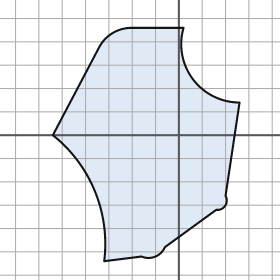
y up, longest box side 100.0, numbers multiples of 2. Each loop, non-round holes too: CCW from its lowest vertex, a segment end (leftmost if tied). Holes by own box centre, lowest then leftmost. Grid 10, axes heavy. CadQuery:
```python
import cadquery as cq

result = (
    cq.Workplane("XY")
    .moveTo(-32.0, -54.0)
    .lineTo(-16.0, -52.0)
    .threePointArc((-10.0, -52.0), (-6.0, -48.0))
    .lineTo(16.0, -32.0)
    .threePointArc((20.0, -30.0), (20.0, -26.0))
    .lineTo(26.0, 14.0)
    .threePointArc((6.0, 24.0), (2.0, 46.0))
    .lineTo(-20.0, 46.0)
    .threePointArc((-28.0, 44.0), (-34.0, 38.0))
    .lineTo(-54.0, 0.0)
    .threePointArc((-36.0, -24.0), (-32.0, -54.0))
    .close()
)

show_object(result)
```